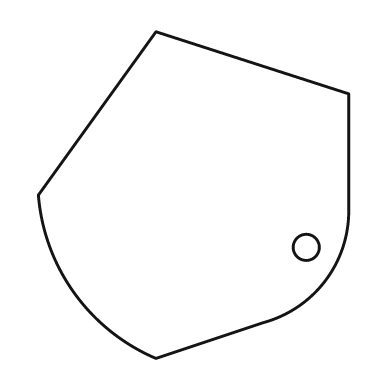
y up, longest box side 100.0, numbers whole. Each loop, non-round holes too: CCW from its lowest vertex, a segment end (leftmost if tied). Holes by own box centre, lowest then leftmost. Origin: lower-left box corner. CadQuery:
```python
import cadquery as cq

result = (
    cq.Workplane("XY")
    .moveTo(36.0, 0.0)
    .lineTo(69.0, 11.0)
    .threePointArc((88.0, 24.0), (95.0, 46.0))
    .lineTo(95.0, 81.0)
    .lineTo(36.0, 100.0)
    .lineTo(0.0, 50.0)
    .threePointArc((11.0, 20.0), (36.0, 0.0))
    .close()
    .moveTo(82.0, 34.0)
    .circle(4.0)
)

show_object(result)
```